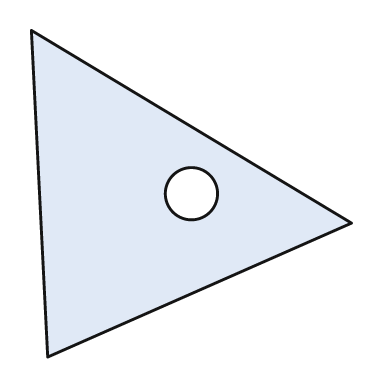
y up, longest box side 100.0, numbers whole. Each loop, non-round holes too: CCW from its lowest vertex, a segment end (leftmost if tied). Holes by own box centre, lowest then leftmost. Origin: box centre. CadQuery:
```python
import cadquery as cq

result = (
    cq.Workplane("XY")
    .moveTo(-44.0, -50.0)
    .lineTo(49.0, -9.0)
    .lineTo(-49.0, 50.0)
    .close()
    .moveTo(0.0, 0.0)
    .circle(8.0)
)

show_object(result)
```